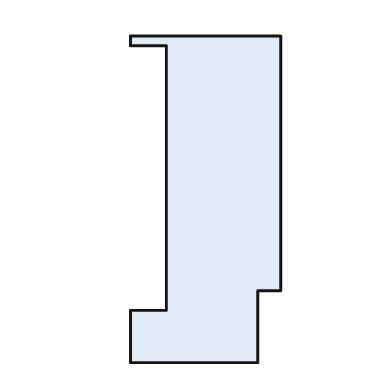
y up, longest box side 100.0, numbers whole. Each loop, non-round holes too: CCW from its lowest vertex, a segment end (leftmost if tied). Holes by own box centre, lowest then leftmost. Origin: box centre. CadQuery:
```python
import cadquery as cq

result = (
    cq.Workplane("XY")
    .moveTo(-23.0, -50.0)
    .lineTo(16.0, -50.0)
    .lineTo(16.0, -28.0)
    .lineTo(23.0, -28.0)
    .lineTo(23.0, 50.0)
    .lineTo(-23.0, 50.0)
    .lineTo(-23.0, 47.0)
    .lineTo(-12.0, 47.0)
    .lineTo(-12.0, -34.0)
    .lineTo(-23.0, -34.0)
    .close()
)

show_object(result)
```